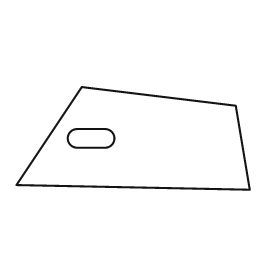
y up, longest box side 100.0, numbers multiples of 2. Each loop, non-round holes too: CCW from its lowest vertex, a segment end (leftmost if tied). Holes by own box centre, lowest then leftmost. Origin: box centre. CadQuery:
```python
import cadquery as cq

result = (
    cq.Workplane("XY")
    .moveTo(50.0, -22.0)
    .lineTo(44.0, 14.0)
    .lineTo(-22.0, 22.0)
    .lineTo(-50.0, -20.0)
    .close()
    .moveTo(-24.0, -4.0)
    .lineTo(-12.0, -4.0)
    .threePointArc((-8.0, 0.0), (-12.0, 4.0))
    .lineTo(-24.0, 4.0)
    .threePointArc((-28.0, 0.0), (-24.0, -4.0))
    .close()
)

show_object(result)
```